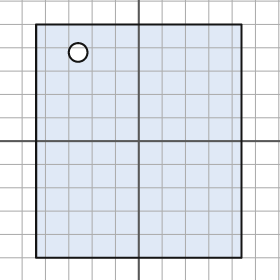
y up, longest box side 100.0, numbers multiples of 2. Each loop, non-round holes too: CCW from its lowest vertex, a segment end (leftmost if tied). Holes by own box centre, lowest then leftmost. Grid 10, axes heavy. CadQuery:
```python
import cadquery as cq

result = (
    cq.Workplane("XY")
    .moveTo(-44.0, -50.0)
    .lineTo(44.0, -50.0)
    .lineTo(44.0, 50.0)
    .lineTo(-44.0, 50.0)
    .close()
    .moveTo(-26.0, 38.0)
    .circle(4.0)
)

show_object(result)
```